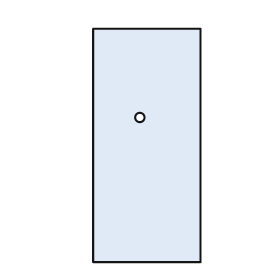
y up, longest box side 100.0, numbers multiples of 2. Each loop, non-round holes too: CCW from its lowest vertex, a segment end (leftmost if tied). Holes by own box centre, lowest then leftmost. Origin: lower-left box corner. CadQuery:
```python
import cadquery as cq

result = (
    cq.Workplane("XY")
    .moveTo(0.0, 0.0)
    .lineTo(46.0, 0.0)
    .lineTo(46.0, 100.0)
    .lineTo(0.0, 100.0)
    .close()
    .moveTo(20.0, 62.0)
    .circle(2.0)
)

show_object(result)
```